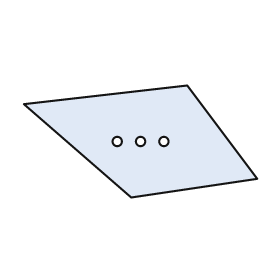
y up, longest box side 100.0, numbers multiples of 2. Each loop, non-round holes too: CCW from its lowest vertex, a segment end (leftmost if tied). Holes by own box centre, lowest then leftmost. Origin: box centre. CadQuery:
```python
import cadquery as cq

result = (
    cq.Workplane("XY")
    .moveTo(-4.0, -24.0)
    .lineTo(50.0, -16.0)
    .lineTo(20.0, 24.0)
    .lineTo(-50.0, 16.0)
    .close()
    .moveTo(-10.0, 0.0)
    .circle(2.0)
    .moveTo(0.0, 0.0)
    .circle(2.0)
    .moveTo(10.0, 0.0)
    .circle(2.0)
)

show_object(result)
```